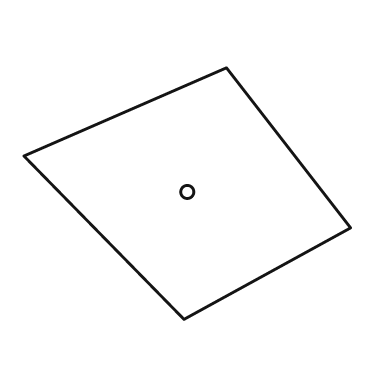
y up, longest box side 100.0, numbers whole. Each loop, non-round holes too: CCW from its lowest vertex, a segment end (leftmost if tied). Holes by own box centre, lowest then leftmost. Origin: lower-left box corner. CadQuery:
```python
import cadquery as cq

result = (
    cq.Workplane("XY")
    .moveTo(49.0, 0.0)
    .lineTo(100.0, 28.0)
    .lineTo(62.0, 77.0)
    .lineTo(0.0, 50.0)
    .close()
    .moveTo(50.0, 39.0)
    .circle(2.0)
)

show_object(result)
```